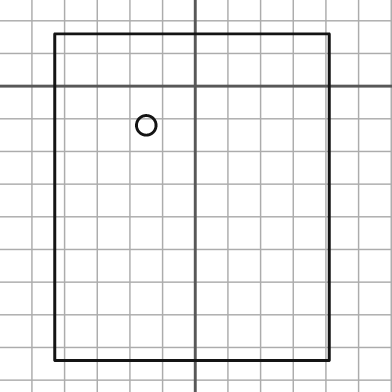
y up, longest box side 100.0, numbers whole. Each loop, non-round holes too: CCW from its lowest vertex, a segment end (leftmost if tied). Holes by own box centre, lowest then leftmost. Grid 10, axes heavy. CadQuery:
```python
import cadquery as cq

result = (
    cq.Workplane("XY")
    .moveTo(-43.0, -84.0)
    .lineTo(41.0, -84.0)
    .lineTo(41.0, 16.0)
    .lineTo(-43.0, 16.0)
    .close()
    .moveTo(-15.0, -12.0)
    .circle(3.0)
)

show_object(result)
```